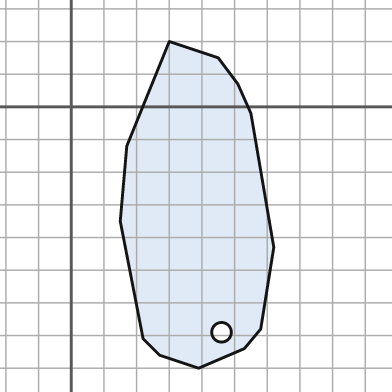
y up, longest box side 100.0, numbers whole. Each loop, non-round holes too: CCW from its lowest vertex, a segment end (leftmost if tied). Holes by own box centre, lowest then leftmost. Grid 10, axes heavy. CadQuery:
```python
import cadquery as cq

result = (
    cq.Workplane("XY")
    .moveTo(39.0, -80.0)
    .lineTo(53.0, -74.0)
    .lineTo(58.0, -68.0)
    .lineTo(62.0, -43.0)
    .lineTo(55.0, -2.0)
    .lineTo(51.0, 7.0)
    .lineTo(45.0, 15.0)
    .lineTo(30.0, 20.0)
    .lineTo(17.0, -12.0)
    .lineTo(15.0, -35.0)
    .lineTo(22.0, -71.0)
    .lineTo(27.0, -76.0)
    .close()
    .moveTo(46.0, -69.0)
    .circle(3.0)
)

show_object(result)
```